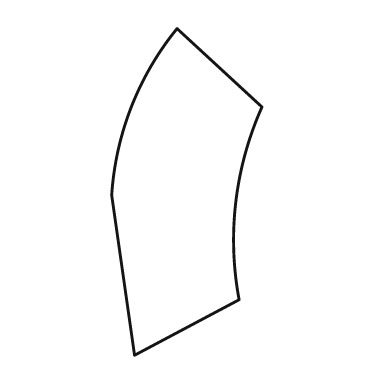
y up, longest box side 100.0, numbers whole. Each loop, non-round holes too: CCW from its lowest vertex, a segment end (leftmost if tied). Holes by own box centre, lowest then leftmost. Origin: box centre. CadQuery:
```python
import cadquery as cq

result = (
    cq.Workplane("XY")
    .moveTo(-16.0, -50.0)
    .lineTo(16.0, -33.0)
    .threePointArc((15.0, -3.0), (23.0, 26.0))
    .lineTo(-3.0, 50.0)
    .threePointArc((-17.0, 26.0), (-23.0, -1.0))
    .close()
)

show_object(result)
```